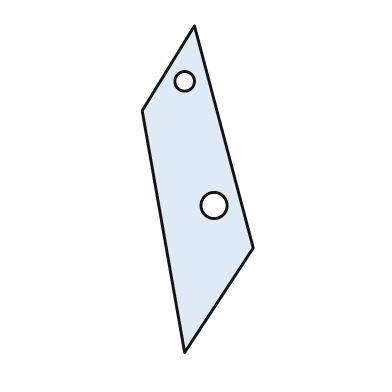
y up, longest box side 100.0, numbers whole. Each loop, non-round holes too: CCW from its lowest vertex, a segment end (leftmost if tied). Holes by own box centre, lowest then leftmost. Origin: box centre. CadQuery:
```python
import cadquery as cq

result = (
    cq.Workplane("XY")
    .moveTo(-4.0, -50.0)
    .lineTo(17.0, -18.0)
    .lineTo(-1.0, 50.0)
    .lineTo(-17.0, 24.0)
    .close()
    .moveTo(5.0, -5.0)
    .circle(4.0)
    .moveTo(-4.0, 33.0)
    .circle(3.0)
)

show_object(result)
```